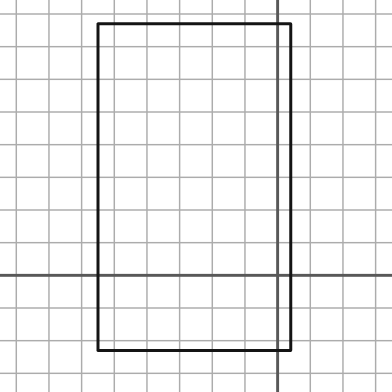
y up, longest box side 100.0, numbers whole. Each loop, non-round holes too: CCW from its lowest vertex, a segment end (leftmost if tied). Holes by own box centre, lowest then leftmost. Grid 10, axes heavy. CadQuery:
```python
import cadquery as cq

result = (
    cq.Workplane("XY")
    .moveTo(-55.0, -23.0)
    .lineTo(4.0, -23.0)
    .lineTo(4.0, 77.0)
    .lineTo(-55.0, 77.0)
    .close()
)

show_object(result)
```